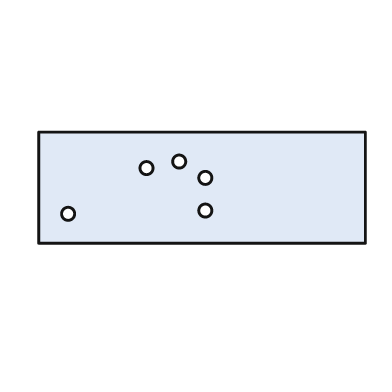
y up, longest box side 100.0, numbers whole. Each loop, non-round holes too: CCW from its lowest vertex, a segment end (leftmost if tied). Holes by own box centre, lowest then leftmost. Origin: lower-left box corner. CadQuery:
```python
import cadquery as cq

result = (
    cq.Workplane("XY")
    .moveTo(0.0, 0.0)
    .lineTo(100.0, 0.0)
    .lineTo(100.0, 34.0)
    .lineTo(0.0, 34.0)
    .close()
    .moveTo(9.0, 9.0)
    .circle(2.0)
    .moveTo(51.0, 10.0)
    .circle(2.0)
    .moveTo(51.0, 20.0)
    .circle(2.0)
    .moveTo(33.0, 23.0)
    .circle(2.0)
    .moveTo(43.0, 25.0)
    .circle(2.0)
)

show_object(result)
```